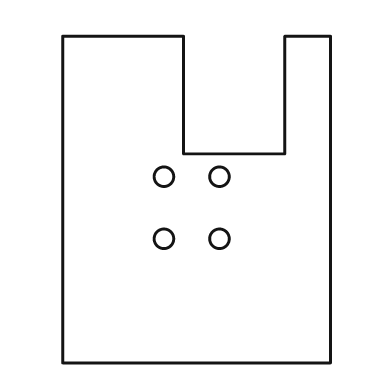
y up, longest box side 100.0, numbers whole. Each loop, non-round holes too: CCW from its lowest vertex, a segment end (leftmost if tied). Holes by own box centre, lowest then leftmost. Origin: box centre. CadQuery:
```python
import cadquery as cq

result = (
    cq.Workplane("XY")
    .moveTo(-41.0, -50.0)
    .lineTo(41.0, -50.0)
    .lineTo(41.0, 50.0)
    .lineTo(27.0, 50.0)
    .lineTo(27.0, 14.0)
    .lineTo(-4.0, 14.0)
    .lineTo(-4.0, 50.0)
    .lineTo(-41.0, 50.0)
    .close()
    .moveTo(-10.0, -12.0)
    .circle(3.0)
    .moveTo(7.0, -12.0)
    .circle(3.0)
    .moveTo(-10.0, 7.0)
    .circle(3.0)
    .moveTo(7.0, 7.0)
    .circle(3.0)
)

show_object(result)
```